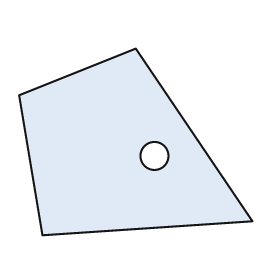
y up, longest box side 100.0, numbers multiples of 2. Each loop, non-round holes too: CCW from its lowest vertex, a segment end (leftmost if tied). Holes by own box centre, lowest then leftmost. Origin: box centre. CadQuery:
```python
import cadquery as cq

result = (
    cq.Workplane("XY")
    .moveTo(-40.0, -40.0)
    .lineTo(50.0, -34.0)
    .lineTo(0.0, 40.0)
    .lineTo(-50.0, 20.0)
    .close()
    .moveTo(8.0, -6.0)
    .circle(6.0)
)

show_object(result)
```